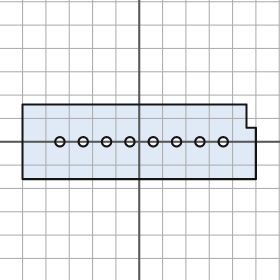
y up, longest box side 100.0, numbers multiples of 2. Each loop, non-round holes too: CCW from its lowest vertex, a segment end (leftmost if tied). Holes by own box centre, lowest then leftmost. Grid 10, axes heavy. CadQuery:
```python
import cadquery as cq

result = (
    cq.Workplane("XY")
    .moveTo(-50.0, -16.0)
    .lineTo(50.0, -16.0)
    .lineTo(50.0, 6.0)
    .lineTo(46.0, 6.0)
    .lineTo(46.0, 16.0)
    .lineTo(-50.0, 16.0)
    .close()
    .moveTo(-34.0, 0.0)
    .circle(2.0)
    .moveTo(-24.0, 0.0)
    .circle(2.0)
    .moveTo(-14.0, 0.0)
    .circle(2.0)
    .moveTo(-4.0, 0.0)
    .circle(2.0)
    .moveTo(6.0, 0.0)
    .circle(2.0)
    .moveTo(16.0, 0.0)
    .circle(2.0)
    .moveTo(26.0, 0.0)
    .circle(2.0)
    .moveTo(36.0, 0.0)
    .circle(2.0)
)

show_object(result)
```